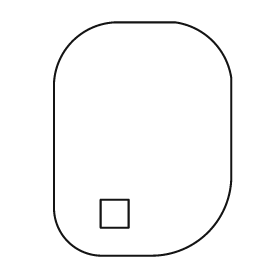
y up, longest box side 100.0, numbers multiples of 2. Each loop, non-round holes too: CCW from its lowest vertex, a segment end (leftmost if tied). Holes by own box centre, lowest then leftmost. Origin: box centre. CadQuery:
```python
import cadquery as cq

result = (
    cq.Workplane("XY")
    .moveTo(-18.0, -50.0)
    .lineTo(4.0, -50.0)
    .threePointArc((28.0, -40.0), (38.0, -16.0))
    .lineTo(38.0, 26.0)
    .threePointArc((30.0, 42.0), (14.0, 50.0))
    .lineTo(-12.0, 50.0)
    .threePointArc((-30.0, 42.0), (-38.0, 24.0))
    .lineTo(-38.0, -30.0)
    .threePointArc((-32.0, -44.0), (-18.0, -50.0))
    .close()
    .moveTo(-18.0, -38.0)
    .lineTo(-6.0, -38.0)
    .lineTo(-6.0, -26.0)
    .lineTo(-18.0, -26.0)
    .close()
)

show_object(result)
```